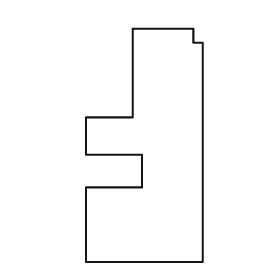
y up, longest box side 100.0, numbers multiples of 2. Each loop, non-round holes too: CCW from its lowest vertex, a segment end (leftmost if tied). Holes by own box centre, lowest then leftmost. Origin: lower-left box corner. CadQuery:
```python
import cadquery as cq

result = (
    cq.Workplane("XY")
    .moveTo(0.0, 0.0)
    .lineTo(50.0, 0.0)
    .lineTo(50.0, 94.0)
    .lineTo(46.0, 94.0)
    .lineTo(46.0, 100.0)
    .lineTo(20.0, 100.0)
    .lineTo(20.0, 62.0)
    .lineTo(0.0, 62.0)
    .lineTo(0.0, 46.0)
    .lineTo(24.0, 46.0)
    .lineTo(24.0, 32.0)
    .lineTo(0.0, 32.0)
    .close()
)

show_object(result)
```